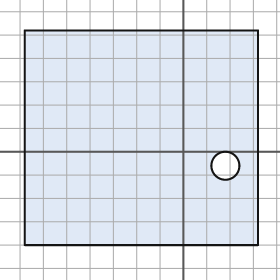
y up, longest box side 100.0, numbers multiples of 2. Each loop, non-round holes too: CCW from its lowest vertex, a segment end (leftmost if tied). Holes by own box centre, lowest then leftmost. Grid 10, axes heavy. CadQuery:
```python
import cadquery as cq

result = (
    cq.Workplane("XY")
    .moveTo(-68.0, -40.0)
    .lineTo(32.0, -40.0)
    .lineTo(32.0, 52.0)
    .lineTo(-68.0, 52.0)
    .close()
    .moveTo(18.0, -6.0)
    .circle(6.0)
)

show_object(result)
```